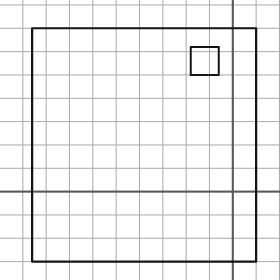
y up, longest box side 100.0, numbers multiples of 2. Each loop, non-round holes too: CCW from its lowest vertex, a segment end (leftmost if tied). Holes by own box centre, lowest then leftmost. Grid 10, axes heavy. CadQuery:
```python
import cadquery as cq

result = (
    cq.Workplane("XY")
    .moveTo(-86.0, -30.0)
    .lineTo(10.0, -30.0)
    .lineTo(10.0, 70.0)
    .lineTo(-86.0, 70.0)
    .close()
    .moveTo(-18.0, 50.0)
    .lineTo(-6.0, 50.0)
    .lineTo(-6.0, 62.0)
    .lineTo(-18.0, 62.0)
    .close()
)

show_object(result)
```